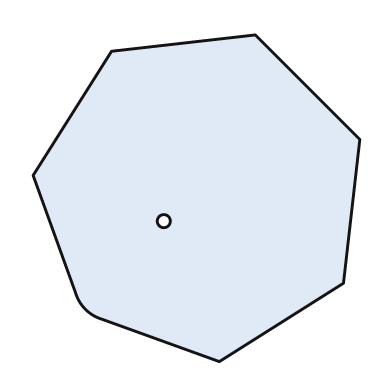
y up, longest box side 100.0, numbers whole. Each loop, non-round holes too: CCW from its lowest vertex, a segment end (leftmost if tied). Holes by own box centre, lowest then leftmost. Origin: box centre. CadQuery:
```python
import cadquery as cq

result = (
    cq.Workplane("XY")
    .moveTo(7.0, -50.0)
    .lineTo(45.0, -26.0)
    .lineTo(50.0, 18.0)
    .lineTo(18.0, 50.0)
    .lineTo(-26.0, 45.0)
    .lineTo(-50.0, 7.0)
    .lineTo(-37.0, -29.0)
    .threePointArc((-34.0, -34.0), (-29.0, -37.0))
    .close()
    .moveTo(-10.0, -7.0)
    .circle(2.0)
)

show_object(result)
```